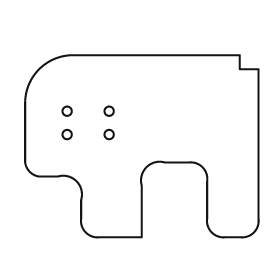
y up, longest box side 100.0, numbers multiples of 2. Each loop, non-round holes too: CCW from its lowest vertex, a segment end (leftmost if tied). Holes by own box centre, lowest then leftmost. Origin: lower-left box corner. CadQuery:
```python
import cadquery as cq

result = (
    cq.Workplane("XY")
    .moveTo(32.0, 0.0)
    .lineTo(50.0, 0.0)
    .lineTo(50.0, 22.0)
    .threePointArc((52.0, 30.0), (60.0, 32.0))
    .lineTo(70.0, 32.0)
    .threePointArc((76.0, 30.0), (78.0, 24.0))
    .lineTo(78.0, 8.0)
    .threePointArc((80.0, 2.0), (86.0, 0.0))
    .lineTo(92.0, 0.0)
    .threePointArc((98.0, 2.0), (100.0, 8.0))
    .lineTo(100.0, 72.0)
    .lineTo(92.0, 72.0)
    .lineTo(92.0, 78.0)
    .lineTo(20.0, 78.0)
    .threePointArc((6.0, 72.0), (0.0, 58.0))
    .lineTo(0.0, 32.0)
    .threePointArc((2.0, 28.0), (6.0, 26.0))
    .lineTo(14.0, 26.0)
    .threePointArc((22.0, 24.0), (24.0, 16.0))
    .lineTo(24.0, 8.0)
    .threePointArc((26.0, 2.0), (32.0, 0.0))
    .close()
    .moveTo(18.0, 44.0)
    .circle(2.0)
    .moveTo(36.0, 44.0)
    .circle(2.0)
    .moveTo(18.0, 54.0)
    .circle(2.0)
    .moveTo(36.0, 54.0)
    .circle(2.0)
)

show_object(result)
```